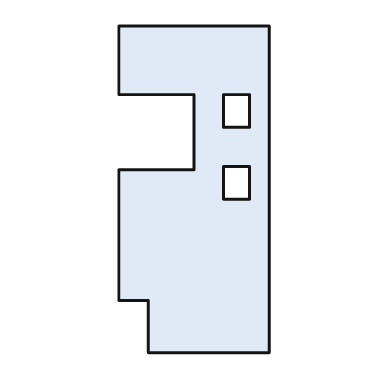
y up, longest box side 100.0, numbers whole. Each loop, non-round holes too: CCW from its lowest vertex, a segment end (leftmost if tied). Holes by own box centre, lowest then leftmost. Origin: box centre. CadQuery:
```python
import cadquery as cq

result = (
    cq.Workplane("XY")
    .moveTo(-14.0, -50.0)
    .lineTo(23.0, -50.0)
    .lineTo(23.0, 50.0)
    .lineTo(-23.0, 50.0)
    .lineTo(-23.0, 29.0)
    .lineTo(0.0, 29.0)
    .lineTo(0.0, 6.0)
    .lineTo(-23.0, 6.0)
    .lineTo(-23.0, -34.0)
    .lineTo(-14.0, -34.0)
    .close()
    .moveTo(9.0, -3.0)
    .lineTo(17.0, -3.0)
    .lineTo(17.0, 7.0)
    .lineTo(9.0, 7.0)
    .close()
    .moveTo(9.0, 19.0)
    .lineTo(17.0, 19.0)
    .lineTo(17.0, 29.0)
    .lineTo(9.0, 29.0)
    .close()
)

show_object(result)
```